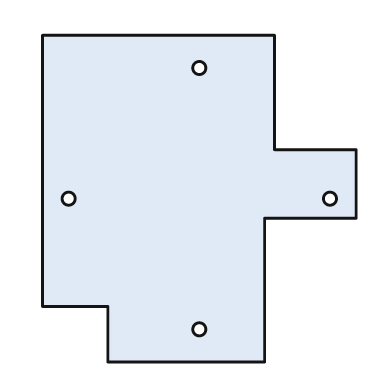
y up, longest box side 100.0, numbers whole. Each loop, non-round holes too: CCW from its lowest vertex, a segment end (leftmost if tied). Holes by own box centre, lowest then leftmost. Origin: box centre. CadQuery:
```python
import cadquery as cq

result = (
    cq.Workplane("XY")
    .moveTo(-28.0, -50.0)
    .lineTo(20.0, -50.0)
    .lineTo(20.0, -6.0)
    .lineTo(48.0, -6.0)
    .lineTo(48.0, 15.0)
    .lineTo(23.0, 15.0)
    .lineTo(23.0, 50.0)
    .lineTo(-48.0, 50.0)
    .lineTo(-48.0, -33.0)
    .lineTo(-28.0, -33.0)
    .close()
    .moveTo(0.0, -40.0)
    .circle(2.0)
    .moveTo(-40.0, 0.0)
    .circle(2.0)
    .moveTo(40.0, 0.0)
    .circle(2.0)
    .moveTo(0.0, 40.0)
    .circle(2.0)
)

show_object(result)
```